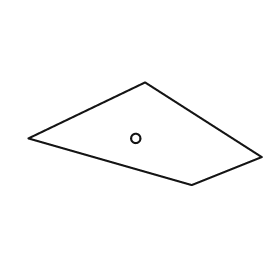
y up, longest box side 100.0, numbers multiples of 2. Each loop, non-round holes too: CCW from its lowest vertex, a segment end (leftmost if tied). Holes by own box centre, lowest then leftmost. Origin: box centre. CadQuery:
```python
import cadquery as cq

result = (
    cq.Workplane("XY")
    .moveTo(20.0, -22.0)
    .lineTo(50.0, -10.0)
    .lineTo(0.0, 22.0)
    .lineTo(-50.0, -2.0)
    .close()
    .moveTo(-4.0, -2.0)
    .circle(2.0)
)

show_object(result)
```